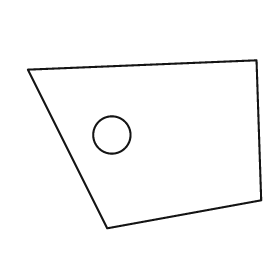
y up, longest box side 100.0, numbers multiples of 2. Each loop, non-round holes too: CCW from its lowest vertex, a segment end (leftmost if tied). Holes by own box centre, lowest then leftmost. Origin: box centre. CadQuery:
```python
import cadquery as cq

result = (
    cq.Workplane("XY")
    .moveTo(-16.0, -36.0)
    .lineTo(50.0, -24.0)
    .lineTo(48.0, 36.0)
    .lineTo(-50.0, 32.0)
    .close()
    .moveTo(-14.0, 4.0)
    .circle(8.0)
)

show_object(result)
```